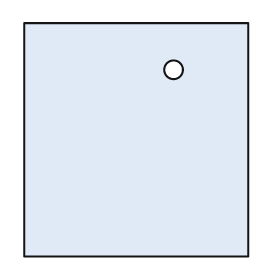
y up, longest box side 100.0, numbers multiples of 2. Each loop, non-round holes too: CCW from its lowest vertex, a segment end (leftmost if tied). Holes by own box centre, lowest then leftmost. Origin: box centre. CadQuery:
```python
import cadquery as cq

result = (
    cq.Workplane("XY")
    .moveTo(-48.0, -50.0)
    .lineTo(48.0, -50.0)
    .lineTo(48.0, 50.0)
    .lineTo(-48.0, 50.0)
    .close()
    .moveTo(16.0, 30.0)
    .circle(4.0)
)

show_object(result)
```